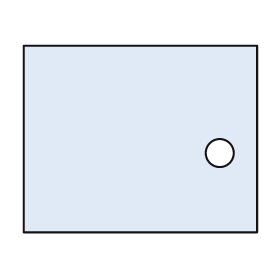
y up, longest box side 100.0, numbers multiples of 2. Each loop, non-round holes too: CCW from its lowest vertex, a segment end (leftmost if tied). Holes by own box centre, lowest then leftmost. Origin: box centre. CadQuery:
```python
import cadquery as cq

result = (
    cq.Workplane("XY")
    .moveTo(-50.0, -40.0)
    .lineTo(50.0, -40.0)
    .lineTo(50.0, 40.0)
    .lineTo(-50.0, 40.0)
    .close()
    .moveTo(34.0, -6.0)
    .circle(6.0)
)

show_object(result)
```